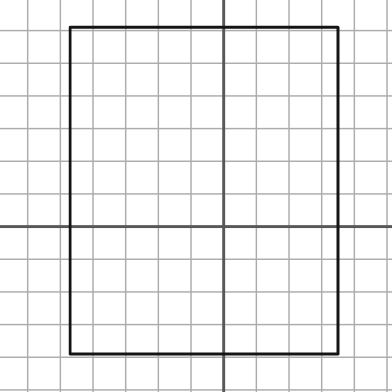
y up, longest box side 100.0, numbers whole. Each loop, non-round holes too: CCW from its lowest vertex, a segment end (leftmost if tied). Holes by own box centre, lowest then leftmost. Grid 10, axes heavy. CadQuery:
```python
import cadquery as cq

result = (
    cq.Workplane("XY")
    .moveTo(-47.0, -39.0)
    .lineTo(35.0, -39.0)
    .lineTo(35.0, 61.0)
    .lineTo(-47.0, 61.0)
    .close()
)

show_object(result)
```